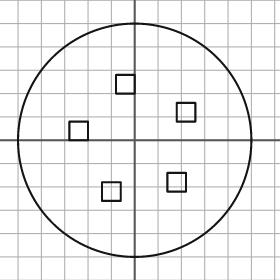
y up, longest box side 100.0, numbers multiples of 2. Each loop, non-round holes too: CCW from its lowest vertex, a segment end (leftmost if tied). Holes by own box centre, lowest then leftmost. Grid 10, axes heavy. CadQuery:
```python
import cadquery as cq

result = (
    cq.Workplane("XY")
    .moveTo(0.0, 0.0)
    .circle(50.0)
    .moveTo(-14.0, -26.0)
    .lineTo(-6.0, -26.0)
    .lineTo(-6.0, -18.0)
    .lineTo(-14.0, -18.0)
    .close()
    .moveTo(14.0, -22.0)
    .lineTo(22.0, -22.0)
    .lineTo(22.0, -14.0)
    .lineTo(14.0, -14.0)
    .close()
    .moveTo(-28.0, 0.0)
    .lineTo(-20.0, 0.0)
    .lineTo(-20.0, 8.0)
    .lineTo(-28.0, 8.0)
    .close()
    .moveTo(18.0, 8.0)
    .lineTo(26.0, 8.0)
    .lineTo(26.0, 16.0)
    .lineTo(18.0, 16.0)
    .close()
    .moveTo(-8.0, 20.0)
    .lineTo(0.0, 20.0)
    .lineTo(0.0, 28.0)
    .lineTo(-8.0, 28.0)
    .close()
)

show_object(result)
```